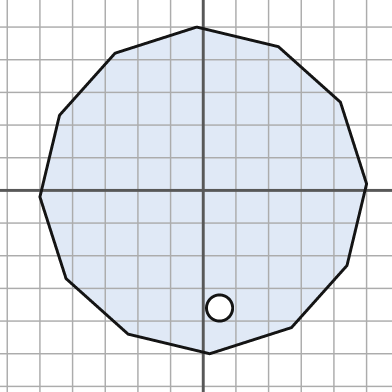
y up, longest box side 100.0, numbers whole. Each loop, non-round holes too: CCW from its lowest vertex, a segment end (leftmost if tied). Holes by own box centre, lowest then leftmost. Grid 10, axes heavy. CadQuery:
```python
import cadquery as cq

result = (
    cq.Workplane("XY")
    .moveTo(2.0, -50.0)
    .lineTo(27.0, -42.0)
    .lineTo(44.0, -23.0)
    .lineTo(50.0, 2.0)
    .lineTo(42.0, 27.0)
    .lineTo(23.0, 44.0)
    .lineTo(-2.0, 50.0)
    .lineTo(-27.0, 42.0)
    .lineTo(-44.0, 23.0)
    .lineTo(-50.0, -2.0)
    .lineTo(-42.0, -27.0)
    .lineTo(-23.0, -44.0)
    .close()
    .moveTo(5.0, -36.0)
    .circle(4.0)
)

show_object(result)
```